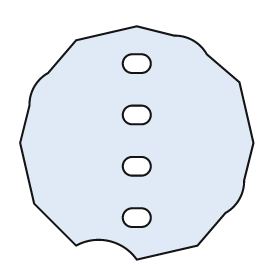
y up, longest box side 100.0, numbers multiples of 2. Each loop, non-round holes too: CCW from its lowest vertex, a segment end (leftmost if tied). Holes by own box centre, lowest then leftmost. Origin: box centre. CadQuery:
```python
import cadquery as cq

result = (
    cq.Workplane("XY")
    .moveTo(0.0, -50.0)
    .lineTo(26.0, -44.0)
    .lineTo(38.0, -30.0)
    .threePointArc((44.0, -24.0), (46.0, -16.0))
    .lineTo(50.0, 0.0)
    .lineTo(44.0, 26.0)
    .lineTo(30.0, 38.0)
    .threePointArc((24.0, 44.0), (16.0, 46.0))
    .lineTo(0.0, 50.0)
    .lineTo(-26.0, 44.0)
    .lineTo(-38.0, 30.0)
    .threePointArc((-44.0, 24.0), (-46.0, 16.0))
    .lineTo(-50.0, 0.0)
    .lineTo(-44.0, -26.0)
    .lineTo(-26.0, -44.0)
    .threePointArc((-12.0, -42.0), (0.0, -50.0))
    .close()
    .moveTo(-2.0, -36.0)
    .lineTo(2.0, -36.0)
    .threePointArc((6.0, -32.0), (2.0, -28.0))
    .lineTo(-2.0, -28.0)
    .threePointArc((-6.0, -32.0), (-2.0, -36.0))
    .close()
    .moveTo(-2.0, -14.0)
    .lineTo(2.0, -14.0)
    .threePointArc((6.0, -10.0), (2.0, -6.0))
    .lineTo(-2.0, -6.0)
    .threePointArc((-6.0, -10.0), (-2.0, -14.0))
    .close()
    .moveTo(-2.0, 8.0)
    .lineTo(2.0, 8.0)
    .threePointArc((6.0, 12.0), (2.0, 16.0))
    .lineTo(-2.0, 16.0)
    .threePointArc((-6.0, 12.0), (-2.0, 8.0))
    .close()
    .moveTo(-2.0, 30.0)
    .lineTo(2.0, 30.0)
    .threePointArc((6.0, 34.0), (2.0, 38.0))
    .lineTo(-2.0, 38.0)
    .threePointArc((-6.0, 34.0), (-2.0, 30.0))
    .close()
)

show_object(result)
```